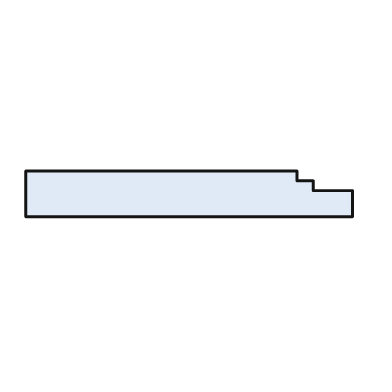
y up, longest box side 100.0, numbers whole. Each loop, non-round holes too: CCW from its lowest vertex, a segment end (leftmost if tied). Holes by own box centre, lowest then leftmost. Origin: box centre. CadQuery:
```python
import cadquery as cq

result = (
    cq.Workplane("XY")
    .moveTo(-50.0, -7.0)
    .lineTo(50.0, -7.0)
    .lineTo(50.0, 1.0)
    .lineTo(38.0, 1.0)
    .lineTo(38.0, 4.0)
    .lineTo(33.0, 4.0)
    .lineTo(33.0, 7.0)
    .lineTo(-50.0, 7.0)
    .close()
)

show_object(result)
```